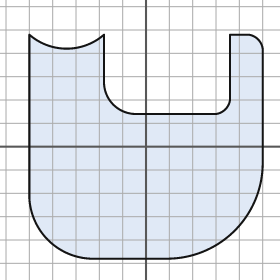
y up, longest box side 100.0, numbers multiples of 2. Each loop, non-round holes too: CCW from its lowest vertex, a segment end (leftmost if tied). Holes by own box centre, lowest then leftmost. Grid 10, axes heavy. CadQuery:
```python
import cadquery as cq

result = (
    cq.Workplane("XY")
    .moveTo(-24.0, -48.0)
    .lineTo(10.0, -48.0)
    .threePointArc((38.0, -36.0), (50.0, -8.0))
    .lineTo(50.0, 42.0)
    .threePointArc((48.0, 46.0), (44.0, 48.0))
    .lineTo(36.0, 48.0)
    .lineTo(36.0, 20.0)
    .threePointArc((34.0, 16.0), (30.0, 14.0))
    .lineTo(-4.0, 14.0)
    .threePointArc((-14.0, 18.0), (-18.0, 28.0))
    .lineTo(-18.0, 48.0)
    .threePointArc((-34.0, 42.0), (-50.0, 48.0))
    .lineTo(-50.0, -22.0)
    .threePointArc((-42.0, -40.0), (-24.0, -48.0))
    .close()
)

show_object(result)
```